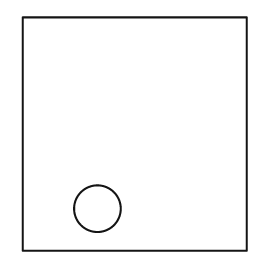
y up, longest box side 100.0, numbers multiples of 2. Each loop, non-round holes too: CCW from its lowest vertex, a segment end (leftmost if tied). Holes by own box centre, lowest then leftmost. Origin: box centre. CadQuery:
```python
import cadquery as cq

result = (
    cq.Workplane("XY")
    .moveTo(-48.0, -50.0)
    .lineTo(48.0, -50.0)
    .lineTo(48.0, 50.0)
    .lineTo(-48.0, 50.0)
    .close()
    .moveTo(-16.0, -32.0)
    .circle(10.0)
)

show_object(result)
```